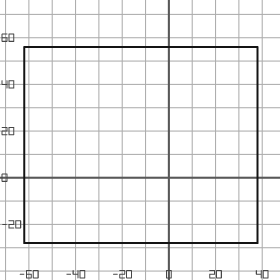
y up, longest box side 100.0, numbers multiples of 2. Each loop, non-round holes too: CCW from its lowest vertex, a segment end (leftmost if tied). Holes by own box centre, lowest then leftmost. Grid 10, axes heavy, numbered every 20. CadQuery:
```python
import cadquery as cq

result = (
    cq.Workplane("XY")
    .moveTo(-62.0, -28.0)
    .lineTo(38.0, -28.0)
    .lineTo(38.0, 56.0)
    .lineTo(-62.0, 56.0)
    .close()
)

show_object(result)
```